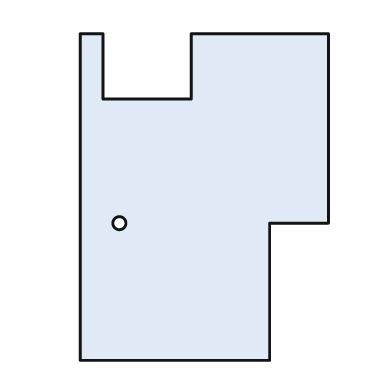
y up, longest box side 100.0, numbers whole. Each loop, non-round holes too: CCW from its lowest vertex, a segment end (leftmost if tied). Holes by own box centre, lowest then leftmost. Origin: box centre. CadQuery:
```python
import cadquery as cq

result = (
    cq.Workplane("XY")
    .moveTo(-38.0, -50.0)
    .lineTo(20.0, -50.0)
    .lineTo(20.0, -8.0)
    .lineTo(38.0, -8.0)
    .lineTo(38.0, 50.0)
    .lineTo(-4.0, 50.0)
    .lineTo(-4.0, 30.0)
    .lineTo(-31.0, 30.0)
    .lineTo(-31.0, 50.0)
    .lineTo(-38.0, 50.0)
    .close()
    .moveTo(-26.0, -8.0)
    .circle(2.0)
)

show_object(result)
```